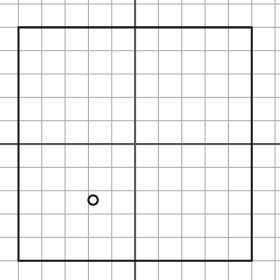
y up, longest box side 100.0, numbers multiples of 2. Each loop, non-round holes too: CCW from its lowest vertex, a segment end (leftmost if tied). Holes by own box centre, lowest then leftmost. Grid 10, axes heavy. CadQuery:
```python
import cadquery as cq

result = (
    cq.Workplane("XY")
    .moveTo(-50.0, -50.0)
    .lineTo(50.0, -50.0)
    .lineTo(50.0, 50.0)
    .lineTo(-50.0, 50.0)
    .close()
    .moveTo(-18.0, -24.0)
    .circle(2.0)
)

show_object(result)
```